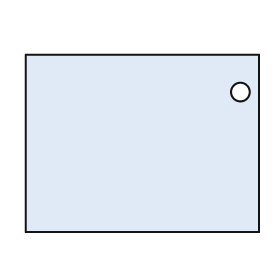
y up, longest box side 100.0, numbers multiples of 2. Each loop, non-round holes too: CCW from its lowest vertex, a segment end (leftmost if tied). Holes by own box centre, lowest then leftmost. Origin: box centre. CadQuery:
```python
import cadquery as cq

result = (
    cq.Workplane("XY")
    .moveTo(-50.0, -38.0)
    .lineTo(50.0, -38.0)
    .lineTo(50.0, 38.0)
    .lineTo(-50.0, 38.0)
    .close()
    .moveTo(42.0, 22.0)
    .circle(4.0)
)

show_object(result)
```